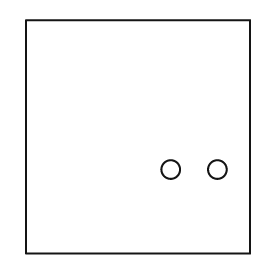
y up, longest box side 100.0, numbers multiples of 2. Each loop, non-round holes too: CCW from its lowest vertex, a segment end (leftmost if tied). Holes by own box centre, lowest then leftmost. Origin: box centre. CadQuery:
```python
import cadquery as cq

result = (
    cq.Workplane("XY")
    .moveTo(-48.0, -50.0)
    .lineTo(48.0, -50.0)
    .lineTo(48.0, 50.0)
    .lineTo(-48.0, 50.0)
    .close()
    .moveTo(14.0, -14.0)
    .circle(4.0)
    .moveTo(34.0, -14.0)
    .circle(4.0)
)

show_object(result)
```